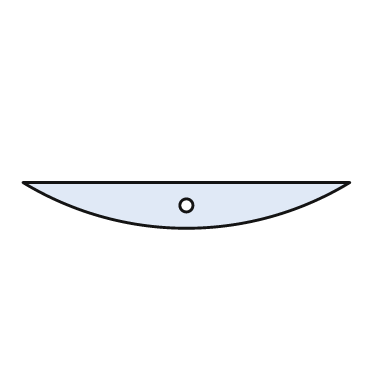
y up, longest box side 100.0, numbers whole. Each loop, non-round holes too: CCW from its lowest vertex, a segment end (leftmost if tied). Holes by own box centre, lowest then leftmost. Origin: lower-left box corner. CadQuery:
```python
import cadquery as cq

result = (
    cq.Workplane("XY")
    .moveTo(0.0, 14.0)
    .threePointArc((50.0, 0.0), (100.0, 14.0))
    .close()
    .moveTo(50.0, 7.0)
    .circle(2.0)
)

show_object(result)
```